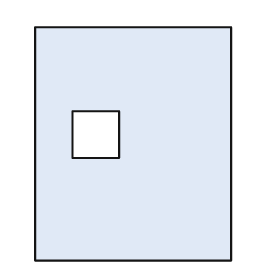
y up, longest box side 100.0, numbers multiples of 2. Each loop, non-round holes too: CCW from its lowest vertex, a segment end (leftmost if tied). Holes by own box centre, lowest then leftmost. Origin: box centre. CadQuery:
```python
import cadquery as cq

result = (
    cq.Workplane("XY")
    .moveTo(-42.0, -50.0)
    .lineTo(42.0, -50.0)
    .lineTo(42.0, 50.0)
    .lineTo(-42.0, 50.0)
    .close()
    .moveTo(-26.0, -6.0)
    .lineTo(-6.0, -6.0)
    .lineTo(-6.0, 14.0)
    .lineTo(-26.0, 14.0)
    .close()
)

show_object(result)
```